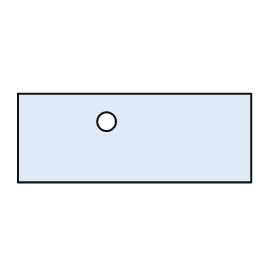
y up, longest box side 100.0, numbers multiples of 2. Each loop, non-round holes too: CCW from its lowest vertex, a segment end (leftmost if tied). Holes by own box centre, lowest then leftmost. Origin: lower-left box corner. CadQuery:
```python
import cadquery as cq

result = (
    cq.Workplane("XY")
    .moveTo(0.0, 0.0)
    .lineTo(100.0, 0.0)
    .lineTo(100.0, 38.0)
    .lineTo(0.0, 38.0)
    .close()
    .moveTo(38.0, 26.0)
    .circle(4.0)
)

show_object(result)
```